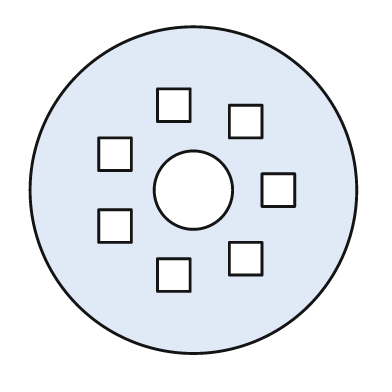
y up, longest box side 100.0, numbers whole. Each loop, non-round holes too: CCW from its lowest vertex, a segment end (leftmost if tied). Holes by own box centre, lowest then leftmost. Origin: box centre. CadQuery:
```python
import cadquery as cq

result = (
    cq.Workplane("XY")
    .moveTo(0.0, 0.0)
    .circle(50.0)
    .moveTo(-11.0, -31.0)
    .lineTo(-1.0, -31.0)
    .lineTo(-1.0, -21.0)
    .lineTo(-11.0, -21.0)
    .close()
    .moveTo(11.0, -26.0)
    .lineTo(21.0, -26.0)
    .lineTo(21.0, -16.0)
    .lineTo(11.0, -16.0)
    .close()
    .moveTo(-29.0, -16.0)
    .lineTo(-19.0, -16.0)
    .lineTo(-19.0, -6.0)
    .lineTo(-29.0, -6.0)
    .close()
    .moveTo(0.0, 0.0)
    .circle(12.0)
    .moveTo(21.0, -5.0)
    .lineTo(31.0, -5.0)
    .lineTo(31.0, 5.0)
    .lineTo(21.0, 5.0)
    .close()
    .moveTo(-29.0, 6.0)
    .lineTo(-19.0, 6.0)
    .lineTo(-19.0, 16.0)
    .lineTo(-29.0, 16.0)
    .close()
    .moveTo(11.0, 16.0)
    .lineTo(21.0, 16.0)
    .lineTo(21.0, 26.0)
    .lineTo(11.0, 26.0)
    .close()
    .moveTo(-11.0, 21.0)
    .lineTo(-1.0, 21.0)
    .lineTo(-1.0, 31.0)
    .lineTo(-11.0, 31.0)
    .close()
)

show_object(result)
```